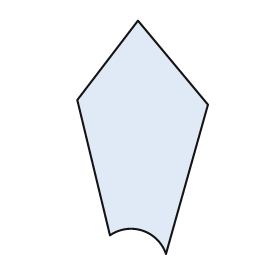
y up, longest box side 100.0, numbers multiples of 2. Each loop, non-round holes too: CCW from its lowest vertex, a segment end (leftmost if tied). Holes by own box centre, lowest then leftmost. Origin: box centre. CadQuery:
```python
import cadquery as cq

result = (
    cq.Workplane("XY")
    .moveTo(10.0, -50.0)
    .lineTo(28.0, 14.0)
    .lineTo(-2.0, 50.0)
    .lineTo(-28.0, 16.0)
    .lineTo(-14.0, -42.0)
    .threePointArc((0.0, -40.0), (10.0, -50.0))
    .close()
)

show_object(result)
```